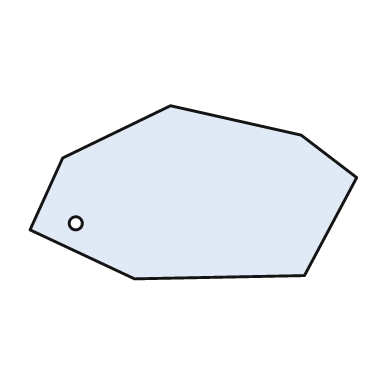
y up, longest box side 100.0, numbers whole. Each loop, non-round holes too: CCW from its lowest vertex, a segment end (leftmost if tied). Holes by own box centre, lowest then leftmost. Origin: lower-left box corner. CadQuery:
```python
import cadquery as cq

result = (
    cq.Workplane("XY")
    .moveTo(32.0, 0.0)
    .lineTo(84.0, 1.0)
    .lineTo(100.0, 31.0)
    .lineTo(83.0, 44.0)
    .lineTo(43.0, 53.0)
    .lineTo(10.0, 37.0)
    .lineTo(0.0, 15.0)
    .close()
    .moveTo(14.0, 17.0)
    .circle(2.0)
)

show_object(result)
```